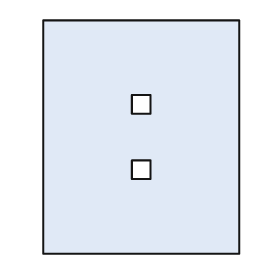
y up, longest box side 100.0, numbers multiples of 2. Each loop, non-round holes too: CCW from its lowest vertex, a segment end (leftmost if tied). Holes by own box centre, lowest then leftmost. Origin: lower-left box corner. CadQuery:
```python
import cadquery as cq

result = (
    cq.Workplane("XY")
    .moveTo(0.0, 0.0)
    .lineTo(84.0, 0.0)
    .lineTo(84.0, 100.0)
    .lineTo(0.0, 100.0)
    .close()
    .moveTo(38.0, 32.0)
    .lineTo(46.0, 32.0)
    .lineTo(46.0, 40.0)
    .lineTo(38.0, 40.0)
    .close()
    .moveTo(38.0, 60.0)
    .lineTo(46.0, 60.0)
    .lineTo(46.0, 68.0)
    .lineTo(38.0, 68.0)
    .close()
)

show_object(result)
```